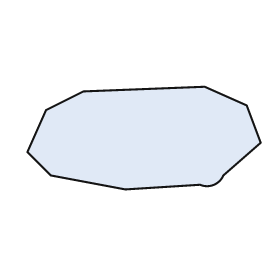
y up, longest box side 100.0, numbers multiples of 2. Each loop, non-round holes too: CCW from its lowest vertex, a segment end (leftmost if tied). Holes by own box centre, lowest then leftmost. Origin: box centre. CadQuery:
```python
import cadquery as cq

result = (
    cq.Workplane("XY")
    .moveTo(-8.0, -22.0)
    .lineTo(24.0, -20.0)
    .threePointArc((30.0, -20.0), (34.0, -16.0))
    .lineTo(50.0, -2.0)
    .lineTo(44.0, 14.0)
    .lineTo(26.0, 22.0)
    .lineTo(-26.0, 20.0)
    .lineTo(-42.0, 12.0)
    .lineTo(-50.0, -6.0)
    .lineTo(-40.0, -16.0)
    .close()
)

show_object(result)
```